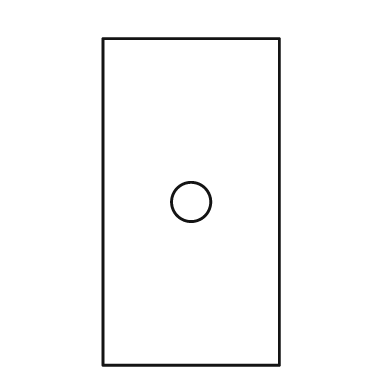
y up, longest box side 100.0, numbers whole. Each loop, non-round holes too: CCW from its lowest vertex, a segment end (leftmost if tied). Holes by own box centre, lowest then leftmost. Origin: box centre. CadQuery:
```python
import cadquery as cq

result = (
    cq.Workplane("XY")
    .moveTo(-27.0, -50.0)
    .lineTo(27.0, -50.0)
    .lineTo(27.0, 50.0)
    .lineTo(-27.0, 50.0)
    .close()
    .moveTo(0.0, 0.0)
    .circle(6.0)
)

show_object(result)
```